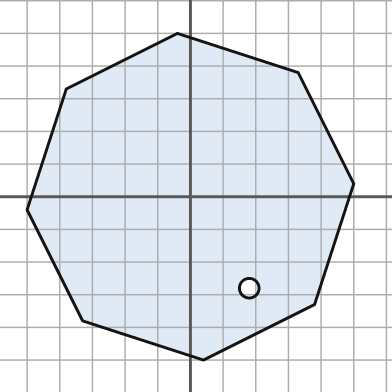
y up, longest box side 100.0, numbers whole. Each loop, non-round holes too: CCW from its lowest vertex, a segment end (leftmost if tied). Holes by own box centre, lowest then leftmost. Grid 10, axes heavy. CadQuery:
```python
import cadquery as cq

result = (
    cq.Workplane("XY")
    .moveTo(4.0, -50.0)
    .lineTo(38.0, -33.0)
    .lineTo(50.0, 4.0)
    .lineTo(33.0, 38.0)
    .lineTo(-4.0, 50.0)
    .lineTo(-38.0, 33.0)
    .lineTo(-50.0, -4.0)
    .lineTo(-33.0, -38.0)
    .close()
    .moveTo(18.0, -28.0)
    .circle(3.0)
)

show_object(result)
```